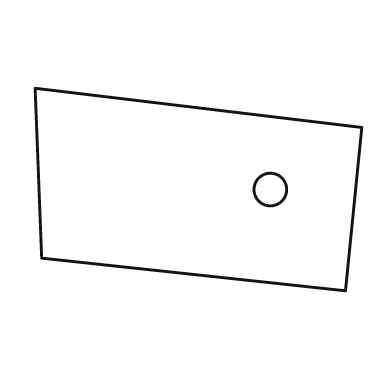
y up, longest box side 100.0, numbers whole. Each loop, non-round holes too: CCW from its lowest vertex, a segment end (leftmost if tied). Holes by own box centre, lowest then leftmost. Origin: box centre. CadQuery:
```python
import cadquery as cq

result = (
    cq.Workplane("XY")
    .moveTo(45.0, -31.0)
    .lineTo(50.0, 19.0)
    .lineTo(-50.0, 31.0)
    .lineTo(-48.0, -21.0)
    .close()
    .moveTo(22.0, 0.0)
    .circle(5.0)
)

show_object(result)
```